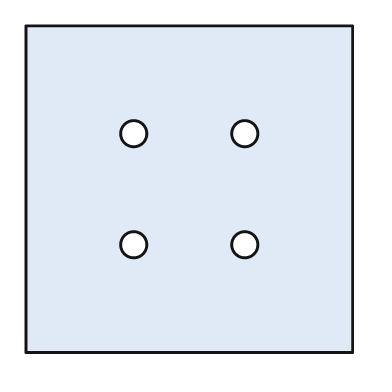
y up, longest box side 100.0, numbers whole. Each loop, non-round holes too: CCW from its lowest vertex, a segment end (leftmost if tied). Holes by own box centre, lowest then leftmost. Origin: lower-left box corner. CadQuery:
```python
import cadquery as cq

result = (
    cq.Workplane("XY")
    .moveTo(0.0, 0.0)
    .lineTo(100.0, 0.0)
    .lineTo(100.0, 100.0)
    .lineTo(0.0, 100.0)
    .close()
    .moveTo(33.0, 33.0)
    .circle(4.0)
    .moveTo(67.0, 33.0)
    .circle(4.0)
    .moveTo(33.0, 67.0)
    .circle(4.0)
    .moveTo(67.0, 67.0)
    .circle(4.0)
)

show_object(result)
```